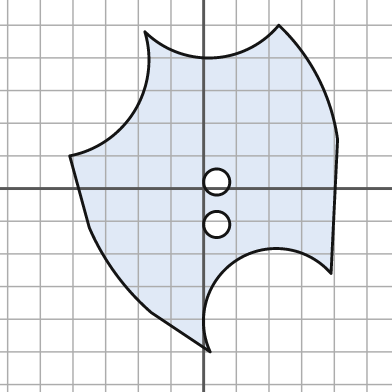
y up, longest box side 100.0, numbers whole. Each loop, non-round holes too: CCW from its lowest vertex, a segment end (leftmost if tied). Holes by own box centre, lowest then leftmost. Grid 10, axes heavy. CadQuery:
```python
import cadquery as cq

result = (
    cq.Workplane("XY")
    .moveTo(2.0, -50.0)
    .threePointArc((10.0, -22.0), (39.0, -26.0))
    .lineTo(41.0, 15.0)
    .threePointArc((35.0, 34.0), (23.0, 50.0))
    .threePointArc((3.0, 40.0), (-18.0, 48.0))
    .threePointArc((-21.0, 24.0), (-41.0, 10.0))
    .lineTo(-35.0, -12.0)
    .threePointArc((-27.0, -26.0), (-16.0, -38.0))
    .close()
    .moveTo(4.0, -11.0)
    .circle(4.0)
    .moveTo(4.0, 2.0)
    .circle(4.0)
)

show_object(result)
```